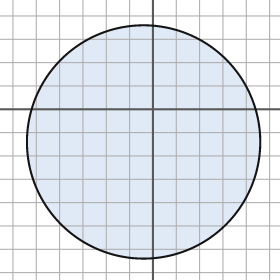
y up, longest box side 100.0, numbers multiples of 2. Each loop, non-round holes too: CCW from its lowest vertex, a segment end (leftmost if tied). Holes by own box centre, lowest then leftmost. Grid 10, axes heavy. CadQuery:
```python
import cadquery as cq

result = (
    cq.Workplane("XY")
    .moveTo(-4.0, -14.0)
    .circle(50.0)
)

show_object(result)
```